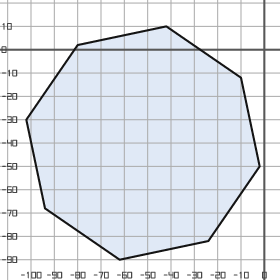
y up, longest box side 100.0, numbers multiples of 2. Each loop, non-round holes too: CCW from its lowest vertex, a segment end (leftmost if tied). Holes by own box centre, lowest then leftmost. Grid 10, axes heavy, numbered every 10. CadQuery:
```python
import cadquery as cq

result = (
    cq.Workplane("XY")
    .moveTo(-62.0, -90.0)
    .lineTo(-24.0, -82.0)
    .lineTo(-2.0, -50.0)
    .lineTo(-10.0, -12.0)
    .lineTo(-42.0, 10.0)
    .lineTo(-80.0, 2.0)
    .lineTo(-102.0, -30.0)
    .lineTo(-94.0, -68.0)
    .close()
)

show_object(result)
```